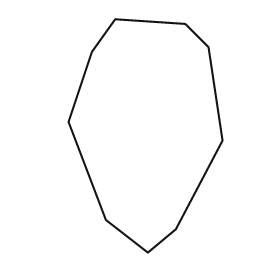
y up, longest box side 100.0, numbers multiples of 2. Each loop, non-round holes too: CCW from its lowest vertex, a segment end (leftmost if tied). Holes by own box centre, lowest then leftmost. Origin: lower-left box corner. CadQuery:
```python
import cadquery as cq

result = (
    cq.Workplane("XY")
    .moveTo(34.0, 0.0)
    .lineTo(46.0, 10.0)
    .lineTo(66.0, 48.0)
    .lineTo(60.0, 88.0)
    .lineTo(50.0, 98.0)
    .lineTo(20.0, 100.0)
    .lineTo(10.0, 86.0)
    .lineTo(0.0, 56.0)
    .lineTo(16.0, 14.0)
    .close()
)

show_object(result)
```